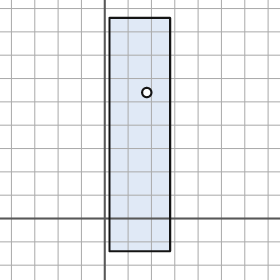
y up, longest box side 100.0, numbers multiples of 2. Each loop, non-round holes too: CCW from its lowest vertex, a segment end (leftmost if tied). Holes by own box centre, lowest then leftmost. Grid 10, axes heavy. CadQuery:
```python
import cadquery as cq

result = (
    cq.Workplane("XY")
    .moveTo(2.0, -14.0)
    .lineTo(28.0, -14.0)
    .lineTo(28.0, 86.0)
    .lineTo(2.0, 86.0)
    .close()
    .moveTo(18.0, 54.0)
    .circle(2.0)
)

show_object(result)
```